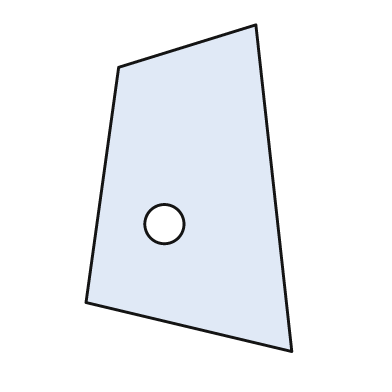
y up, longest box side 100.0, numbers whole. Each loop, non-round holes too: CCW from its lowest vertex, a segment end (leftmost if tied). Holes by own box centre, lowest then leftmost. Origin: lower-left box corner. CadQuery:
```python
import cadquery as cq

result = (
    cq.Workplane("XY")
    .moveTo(63.0, 0.0)
    .lineTo(52.0, 100.0)
    .lineTo(10.0, 87.0)
    .lineTo(0.0, 15.0)
    .close()
    .moveTo(24.0, 39.0)
    .circle(6.0)
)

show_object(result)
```